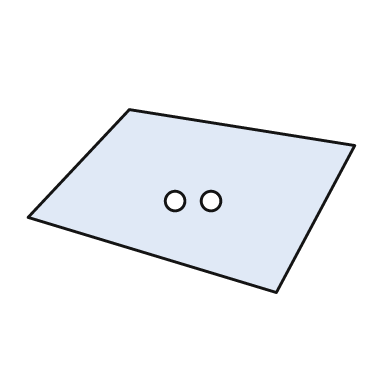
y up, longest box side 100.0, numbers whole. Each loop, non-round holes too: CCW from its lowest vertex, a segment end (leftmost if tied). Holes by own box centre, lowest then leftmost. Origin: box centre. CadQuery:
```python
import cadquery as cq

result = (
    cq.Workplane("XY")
    .moveTo(26.0, -28.0)
    .lineTo(50.0, 17.0)
    .lineTo(-19.0, 28.0)
    .lineTo(-50.0, -5.0)
    .close()
    .moveTo(-5.0, 0.0)
    .circle(3.0)
    .moveTo(6.0, 0.0)
    .circle(3.0)
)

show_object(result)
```